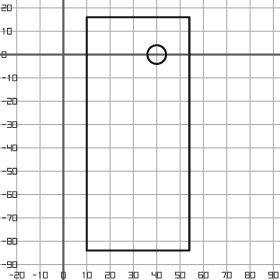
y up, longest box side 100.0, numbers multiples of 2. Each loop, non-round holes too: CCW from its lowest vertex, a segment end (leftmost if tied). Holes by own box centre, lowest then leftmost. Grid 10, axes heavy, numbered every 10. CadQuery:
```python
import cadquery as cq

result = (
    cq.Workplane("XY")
    .moveTo(10.0, -84.0)
    .lineTo(54.0, -84.0)
    .lineTo(54.0, 16.0)
    .lineTo(10.0, 16.0)
    .close()
    .moveTo(40.0, 0.0)
    .circle(4.0)
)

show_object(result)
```